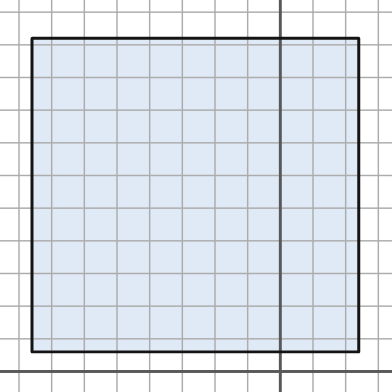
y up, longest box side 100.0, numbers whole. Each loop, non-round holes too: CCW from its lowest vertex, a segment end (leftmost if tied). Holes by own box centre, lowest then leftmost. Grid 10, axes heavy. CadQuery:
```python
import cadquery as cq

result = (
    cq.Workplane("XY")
    .moveTo(-76.0, 6.0)
    .lineTo(24.0, 6.0)
    .lineTo(24.0, 102.0)
    .lineTo(-76.0, 102.0)
    .close()
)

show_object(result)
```